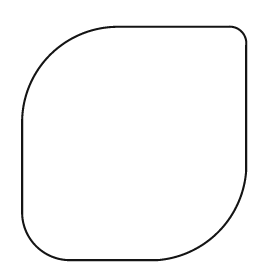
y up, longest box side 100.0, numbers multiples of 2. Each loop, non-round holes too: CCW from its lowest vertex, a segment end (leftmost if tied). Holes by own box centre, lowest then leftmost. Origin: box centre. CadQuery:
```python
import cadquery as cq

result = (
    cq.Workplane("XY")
    .moveTo(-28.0, -50.0)
    .lineTo(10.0, -50.0)
    .threePointArc((36.0, -38.0), (48.0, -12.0))
    .lineTo(48.0, 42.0)
    .threePointArc((46.0, 48.0), (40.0, 50.0))
    .lineTo(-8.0, 50.0)
    .threePointArc((-36.0, 38.0), (-48.0, 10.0))
    .lineTo(-48.0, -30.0)
    .threePointArc((-42.0, -44.0), (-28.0, -50.0))
    .close()
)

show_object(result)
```